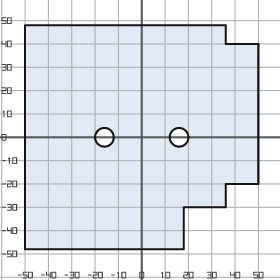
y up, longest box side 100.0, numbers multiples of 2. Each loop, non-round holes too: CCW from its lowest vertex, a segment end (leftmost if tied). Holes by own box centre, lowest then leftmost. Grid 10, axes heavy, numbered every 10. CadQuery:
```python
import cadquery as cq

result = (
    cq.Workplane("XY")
    .moveTo(-50.0, -48.0)
    .lineTo(18.0, -48.0)
    .lineTo(18.0, -30.0)
    .lineTo(36.0, -30.0)
    .lineTo(36.0, -20.0)
    .lineTo(50.0, -20.0)
    .lineTo(50.0, 40.0)
    .lineTo(36.0, 40.0)
    .lineTo(36.0, 48.0)
    .lineTo(-50.0, 48.0)
    .close()
    .moveTo(-16.0, 0.0)
    .circle(4.0)
    .moveTo(16.0, 0.0)
    .circle(4.0)
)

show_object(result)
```